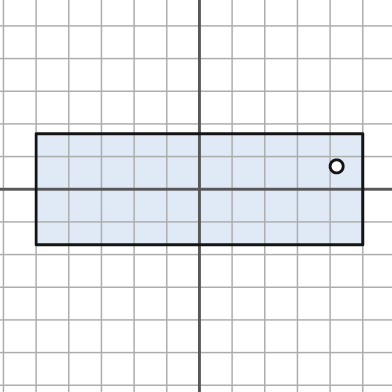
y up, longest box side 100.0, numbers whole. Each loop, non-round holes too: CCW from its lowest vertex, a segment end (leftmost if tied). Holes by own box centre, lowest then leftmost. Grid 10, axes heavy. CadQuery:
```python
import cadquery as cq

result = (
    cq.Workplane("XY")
    .moveTo(-50.0, -17.0)
    .lineTo(50.0, -17.0)
    .lineTo(50.0, 17.0)
    .lineTo(-50.0, 17.0)
    .close()
    .moveTo(42.0, 7.0)
    .circle(2.0)
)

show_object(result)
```